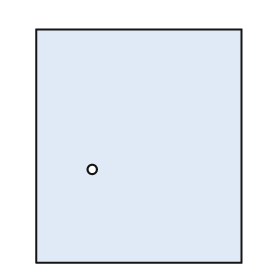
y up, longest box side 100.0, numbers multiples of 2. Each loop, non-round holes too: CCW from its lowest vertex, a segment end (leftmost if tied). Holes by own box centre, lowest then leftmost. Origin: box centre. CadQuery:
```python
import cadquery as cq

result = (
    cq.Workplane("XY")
    .moveTo(-44.0, -50.0)
    .lineTo(44.0, -50.0)
    .lineTo(44.0, 50.0)
    .lineTo(-44.0, 50.0)
    .close()
    .moveTo(-20.0, -10.0)
    .circle(2.0)
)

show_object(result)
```